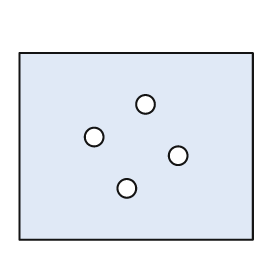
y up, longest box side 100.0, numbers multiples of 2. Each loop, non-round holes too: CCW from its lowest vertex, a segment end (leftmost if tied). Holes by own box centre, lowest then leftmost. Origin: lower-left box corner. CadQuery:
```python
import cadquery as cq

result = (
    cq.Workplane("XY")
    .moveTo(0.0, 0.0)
    .lineTo(100.0, 0.0)
    .lineTo(100.0, 80.0)
    .lineTo(0.0, 80.0)
    .close()
    .moveTo(46.0, 22.0)
    .circle(4.0)
    .moveTo(68.0, 36.0)
    .circle(4.0)
    .moveTo(32.0, 44.0)
    .circle(4.0)
    .moveTo(54.0, 58.0)
    .circle(4.0)
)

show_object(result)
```